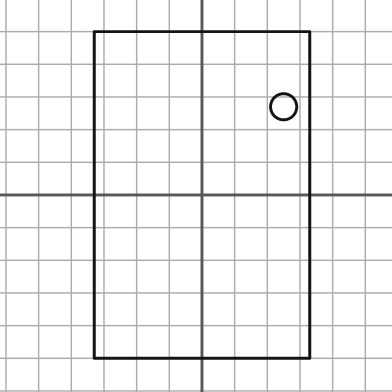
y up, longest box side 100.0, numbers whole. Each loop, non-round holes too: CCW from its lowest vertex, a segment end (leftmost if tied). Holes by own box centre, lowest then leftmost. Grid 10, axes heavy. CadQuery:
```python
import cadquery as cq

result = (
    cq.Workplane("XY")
    .moveTo(-33.0, -50.0)
    .lineTo(33.0, -50.0)
    .lineTo(33.0, 50.0)
    .lineTo(-33.0, 50.0)
    .close()
    .moveTo(25.0, 27.0)
    .circle(4.0)
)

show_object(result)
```